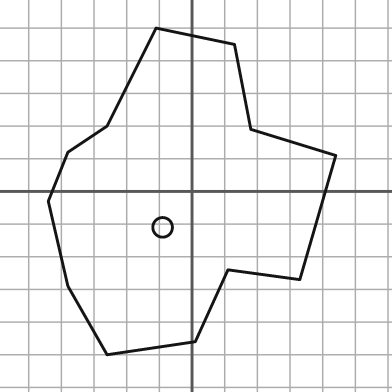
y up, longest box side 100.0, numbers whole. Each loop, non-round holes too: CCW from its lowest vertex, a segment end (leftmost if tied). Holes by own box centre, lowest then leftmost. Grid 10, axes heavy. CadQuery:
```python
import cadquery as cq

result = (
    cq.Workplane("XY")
    .moveTo(-26.0, -50.0)
    .lineTo(1.0, -46.0)
    .lineTo(11.0, -24.0)
    .lineTo(33.0, -27.0)
    .lineTo(44.0, 11.0)
    .lineTo(18.0, 19.0)
    .lineTo(13.0, 45.0)
    .lineTo(-11.0, 50.0)
    .lineTo(-26.0, 20.0)
    .lineTo(-38.0, 12.0)
    .lineTo(-44.0, -3.0)
    .lineTo(-38.0, -29.0)
    .close()
    .moveTo(-9.0, -11.0)
    .circle(3.0)
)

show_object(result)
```